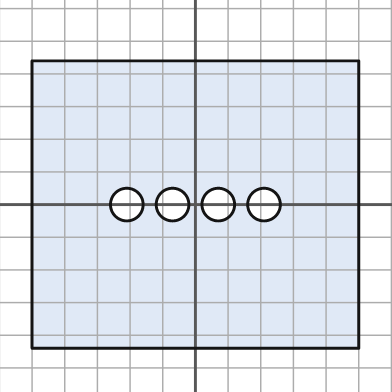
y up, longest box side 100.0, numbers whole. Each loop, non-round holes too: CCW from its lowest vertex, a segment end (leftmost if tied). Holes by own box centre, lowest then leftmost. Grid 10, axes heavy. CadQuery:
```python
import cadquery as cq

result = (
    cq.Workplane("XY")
    .moveTo(-50.0, -44.0)
    .lineTo(50.0, -44.0)
    .lineTo(50.0, 44.0)
    .lineTo(-50.0, 44.0)
    .close()
    .moveTo(-21.0, 0.0)
    .circle(5.0)
    .moveTo(-7.0, 0.0)
    .circle(5.0)
    .moveTo(7.0, 0.0)
    .circle(5.0)
    .moveTo(21.0, 0.0)
    .circle(5.0)
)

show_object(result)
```